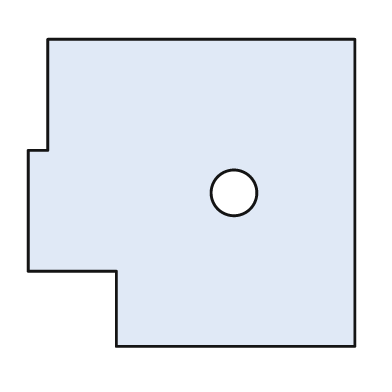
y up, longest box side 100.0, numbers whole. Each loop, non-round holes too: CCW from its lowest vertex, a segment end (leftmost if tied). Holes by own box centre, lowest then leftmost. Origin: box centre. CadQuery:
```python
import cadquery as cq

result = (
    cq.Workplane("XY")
    .moveTo(-23.0, -47.0)
    .lineTo(50.0, -47.0)
    .lineTo(50.0, 47.0)
    .lineTo(-44.0, 47.0)
    .lineTo(-44.0, 13.0)
    .lineTo(-50.0, 13.0)
    .lineTo(-50.0, -24.0)
    .lineTo(-23.0, -24.0)
    .close()
    .moveTo(13.0, 0.0)
    .circle(7.0)
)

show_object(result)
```